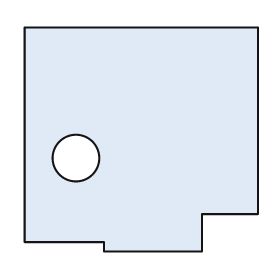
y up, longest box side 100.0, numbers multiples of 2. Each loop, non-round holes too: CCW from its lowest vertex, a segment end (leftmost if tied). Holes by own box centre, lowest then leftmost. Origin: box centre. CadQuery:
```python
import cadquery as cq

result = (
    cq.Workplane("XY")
    .moveTo(-16.0, -48.0)
    .lineTo(26.0, -48.0)
    .lineTo(26.0, -32.0)
    .lineTo(50.0, -32.0)
    .lineTo(50.0, 48.0)
    .lineTo(-50.0, 48.0)
    .lineTo(-50.0, -44.0)
    .lineTo(-16.0, -44.0)
    .close()
    .moveTo(-28.0, -8.0)
    .circle(10.0)
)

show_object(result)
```